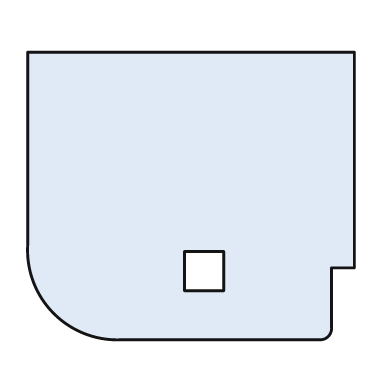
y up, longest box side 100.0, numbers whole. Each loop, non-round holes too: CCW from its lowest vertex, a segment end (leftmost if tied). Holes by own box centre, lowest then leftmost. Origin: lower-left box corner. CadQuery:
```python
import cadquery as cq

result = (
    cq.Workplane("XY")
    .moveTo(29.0, 0.0)
    .lineTo(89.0, 0.0)
    .threePointArc((92.0, 1.0), (93.0, 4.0))
    .lineTo(93.0, 22.0)
    .lineTo(100.0, 22.0)
    .lineTo(100.0, 88.0)
    .lineTo(0.0, 88.0)
    .lineTo(0.0, 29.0)
    .threePointArc((8.0, 8.0), (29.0, 0.0))
    .close()
    .moveTo(48.0, 15.0)
    .lineTo(60.0, 15.0)
    .lineTo(60.0, 27.0)
    .lineTo(48.0, 27.0)
    .close()
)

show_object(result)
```